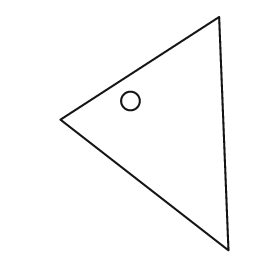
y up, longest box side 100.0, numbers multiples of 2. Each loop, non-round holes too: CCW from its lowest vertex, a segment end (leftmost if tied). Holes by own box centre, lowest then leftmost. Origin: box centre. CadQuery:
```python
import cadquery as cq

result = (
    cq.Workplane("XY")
    .moveTo(36.0, -50.0)
    .lineTo(32.0, 50.0)
    .lineTo(-36.0, 6.0)
    .close()
    .moveTo(-6.0, 14.0)
    .circle(4.0)
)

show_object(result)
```